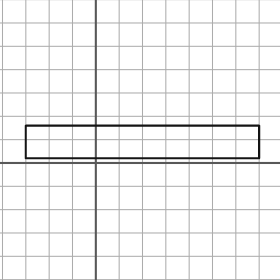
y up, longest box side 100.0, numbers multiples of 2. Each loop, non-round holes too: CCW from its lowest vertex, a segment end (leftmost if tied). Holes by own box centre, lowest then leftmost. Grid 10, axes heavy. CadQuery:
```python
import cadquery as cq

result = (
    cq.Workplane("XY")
    .moveTo(-30.0, 2.0)
    .lineTo(70.0, 2.0)
    .lineTo(70.0, 16.0)
    .lineTo(-30.0, 16.0)
    .close()
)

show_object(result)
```